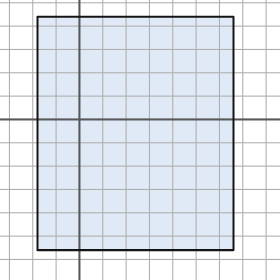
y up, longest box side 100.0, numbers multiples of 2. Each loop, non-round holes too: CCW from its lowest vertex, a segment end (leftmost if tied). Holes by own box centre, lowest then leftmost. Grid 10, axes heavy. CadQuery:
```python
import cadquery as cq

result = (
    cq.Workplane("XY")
    .moveTo(-18.0, -56.0)
    .lineTo(66.0, -56.0)
    .lineTo(66.0, 44.0)
    .lineTo(-18.0, 44.0)
    .close()
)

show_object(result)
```